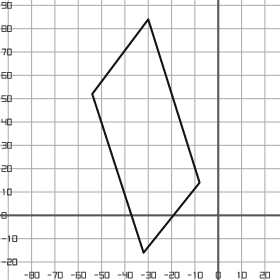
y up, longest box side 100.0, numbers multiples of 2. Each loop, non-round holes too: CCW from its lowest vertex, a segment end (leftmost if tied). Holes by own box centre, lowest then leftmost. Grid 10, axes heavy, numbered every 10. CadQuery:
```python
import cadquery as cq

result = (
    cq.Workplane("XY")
    .moveTo(-32.0, -16.0)
    .lineTo(-8.0, 14.0)
    .lineTo(-30.0, 84.0)
    .lineTo(-54.0, 52.0)
    .close()
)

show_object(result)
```